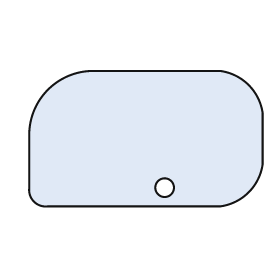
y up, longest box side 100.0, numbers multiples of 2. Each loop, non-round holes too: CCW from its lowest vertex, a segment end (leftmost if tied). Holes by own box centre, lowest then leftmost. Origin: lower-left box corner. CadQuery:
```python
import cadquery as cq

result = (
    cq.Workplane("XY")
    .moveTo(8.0, 0.0)
    .lineTo(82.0, 0.0)
    .threePointArc((94.0, 6.0), (100.0, 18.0))
    .lineTo(100.0, 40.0)
    .threePointArc((94.0, 52.0), (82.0, 58.0))
    .lineTo(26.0, 58.0)
    .threePointArc((8.0, 50.0), (0.0, 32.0))
    .lineTo(0.0, 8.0)
    .threePointArc((2.0, 2.0), (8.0, 0.0))
    .close()
    .moveTo(58.0, 8.0)
    .circle(4.0)
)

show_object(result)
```